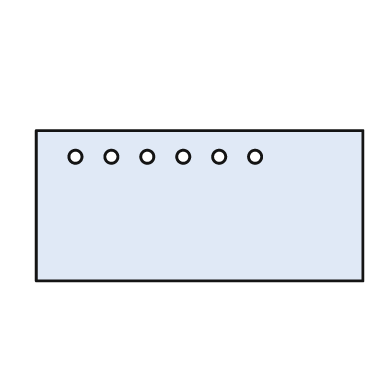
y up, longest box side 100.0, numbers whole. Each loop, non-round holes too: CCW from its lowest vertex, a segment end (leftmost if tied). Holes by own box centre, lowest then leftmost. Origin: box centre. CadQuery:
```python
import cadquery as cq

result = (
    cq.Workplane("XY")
    .moveTo(-50.0, -23.0)
    .lineTo(50.0, -23.0)
    .lineTo(50.0, 23.0)
    .lineTo(-50.0, 23.0)
    .close()
    .moveTo(-38.0, 15.0)
    .circle(2.0)
    .moveTo(-27.0, 15.0)
    .circle(2.0)
    .moveTo(-16.0, 15.0)
    .circle(2.0)
    .moveTo(-5.0, 15.0)
    .circle(2.0)
    .moveTo(6.0, 15.0)
    .circle(2.0)
    .moveTo(17.0, 15.0)
    .circle(2.0)
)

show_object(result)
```